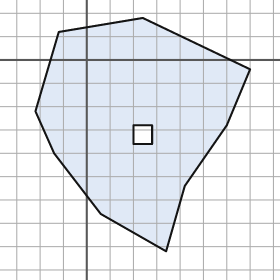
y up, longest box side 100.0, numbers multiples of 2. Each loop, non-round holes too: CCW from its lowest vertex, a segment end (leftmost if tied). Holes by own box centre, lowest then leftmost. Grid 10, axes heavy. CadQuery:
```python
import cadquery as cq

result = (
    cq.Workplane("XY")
    .moveTo(34.0, -82.0)
    .lineTo(42.0, -54.0)
    .lineTo(60.0, -28.0)
    .lineTo(70.0, -4.0)
    .lineTo(24.0, 18.0)
    .lineTo(-12.0, 12.0)
    .lineTo(-22.0, -22.0)
    .lineTo(-14.0, -40.0)
    .lineTo(6.0, -66.0)
    .close()
    .moveTo(20.0, -36.0)
    .lineTo(28.0, -36.0)
    .lineTo(28.0, -28.0)
    .lineTo(20.0, -28.0)
    .close()
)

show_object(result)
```